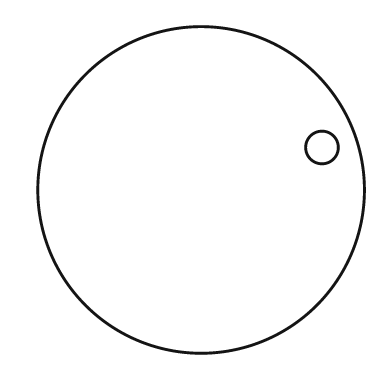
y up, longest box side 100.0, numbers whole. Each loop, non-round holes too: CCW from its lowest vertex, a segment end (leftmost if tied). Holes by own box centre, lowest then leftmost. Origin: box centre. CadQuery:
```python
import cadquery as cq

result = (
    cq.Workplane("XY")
    .moveTo(0.0, 0.0)
    .circle(50.0)
    .moveTo(37.0, 13.0)
    .circle(5.0)
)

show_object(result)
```